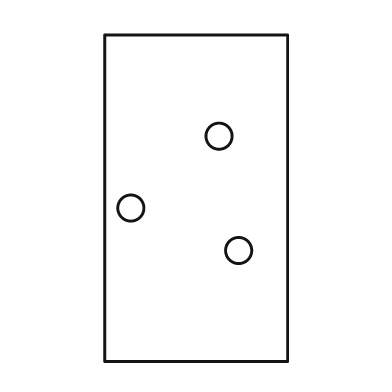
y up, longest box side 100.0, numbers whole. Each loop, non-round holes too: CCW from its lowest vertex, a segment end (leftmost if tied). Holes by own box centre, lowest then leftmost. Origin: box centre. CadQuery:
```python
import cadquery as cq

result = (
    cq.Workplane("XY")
    .moveTo(-28.0, -50.0)
    .lineTo(28.0, -50.0)
    .lineTo(28.0, 50.0)
    .lineTo(-28.0, 50.0)
    .close()
    .moveTo(13.0, -16.0)
    .circle(4.0)
    .moveTo(-20.0, -3.0)
    .circle(4.0)
    .moveTo(7.0, 19.0)
    .circle(4.0)
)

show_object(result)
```